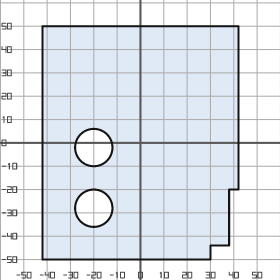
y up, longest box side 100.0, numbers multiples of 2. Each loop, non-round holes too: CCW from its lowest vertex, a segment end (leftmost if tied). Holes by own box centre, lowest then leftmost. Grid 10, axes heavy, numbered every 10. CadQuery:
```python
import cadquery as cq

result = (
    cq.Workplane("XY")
    .moveTo(-42.0, -50.0)
    .lineTo(30.0, -50.0)
    .lineTo(30.0, -44.0)
    .lineTo(38.0, -44.0)
    .lineTo(38.0, -20.0)
    .lineTo(42.0, -20.0)
    .lineTo(42.0, 50.0)
    .lineTo(-42.0, 50.0)
    .close()
    .moveTo(-20.0, -28.0)
    .circle(8.0)
    .moveTo(-20.0, -2.0)
    .circle(8.0)
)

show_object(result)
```